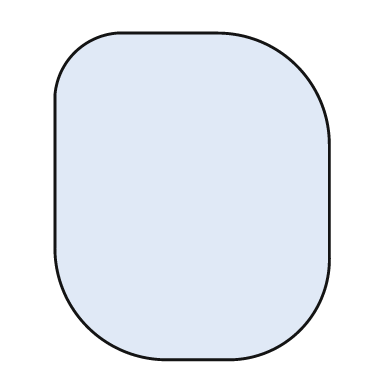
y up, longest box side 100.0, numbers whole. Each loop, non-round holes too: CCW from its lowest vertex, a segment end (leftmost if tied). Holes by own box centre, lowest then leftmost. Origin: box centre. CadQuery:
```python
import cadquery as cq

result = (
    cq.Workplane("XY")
    .moveTo(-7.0, -50.0)
    .lineTo(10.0, -50.0)
    .threePointArc((33.0, -41.0), (42.0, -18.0))
    .lineTo(42.0, 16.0)
    .threePointArc((32.0, 40.0), (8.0, 50.0))
    .lineTo(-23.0, 50.0)
    .threePointArc((-36.0, 44.0), (-42.0, 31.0))
    .lineTo(-42.0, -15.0)
    .threePointArc((-32.0, -40.0), (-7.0, -50.0))
    .close()
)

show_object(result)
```